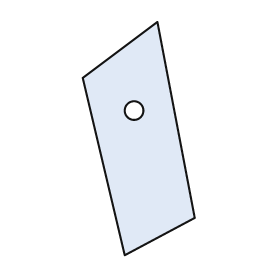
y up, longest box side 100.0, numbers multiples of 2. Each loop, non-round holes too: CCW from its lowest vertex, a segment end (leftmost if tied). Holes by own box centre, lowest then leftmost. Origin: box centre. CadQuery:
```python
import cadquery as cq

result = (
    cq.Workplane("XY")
    .moveTo(-6.0, -50.0)
    .lineTo(24.0, -34.0)
    .lineTo(8.0, 50.0)
    .lineTo(-24.0, 26.0)
    .close()
    .moveTo(-2.0, 12.0)
    .circle(4.0)
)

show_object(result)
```